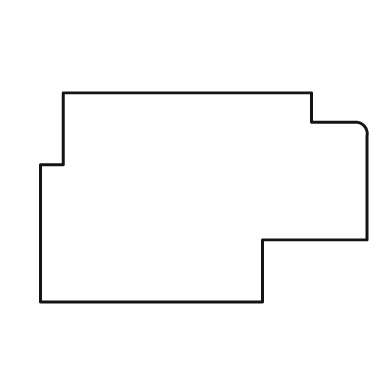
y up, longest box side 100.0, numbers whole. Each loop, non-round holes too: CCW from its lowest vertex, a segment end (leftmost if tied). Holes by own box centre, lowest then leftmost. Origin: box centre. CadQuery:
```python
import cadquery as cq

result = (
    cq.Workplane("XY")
    .moveTo(-50.0, -32.0)
    .lineTo(18.0, -32.0)
    .lineTo(18.0, -13.0)
    .lineTo(50.0, -13.0)
    .lineTo(50.0, 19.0)
    .threePointArc((49.0, 22.0), (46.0, 23.0))
    .lineTo(33.0, 23.0)
    .lineTo(33.0, 32.0)
    .lineTo(-43.0, 32.0)
    .lineTo(-43.0, 10.0)
    .lineTo(-50.0, 10.0)
    .close()
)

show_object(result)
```